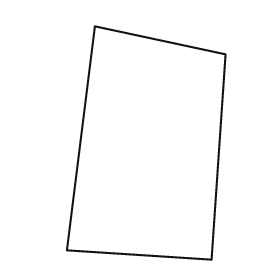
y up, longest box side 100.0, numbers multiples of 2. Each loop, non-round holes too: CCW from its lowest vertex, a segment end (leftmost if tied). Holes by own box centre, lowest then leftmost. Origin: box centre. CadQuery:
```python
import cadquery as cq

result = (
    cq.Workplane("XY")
    .moveTo(28.0, -50.0)
    .lineTo(34.0, 38.0)
    .lineTo(-22.0, 50.0)
    .lineTo(-34.0, -46.0)
    .close()
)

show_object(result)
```